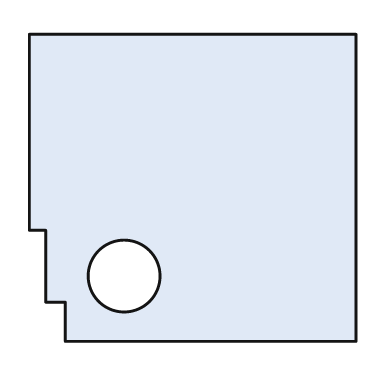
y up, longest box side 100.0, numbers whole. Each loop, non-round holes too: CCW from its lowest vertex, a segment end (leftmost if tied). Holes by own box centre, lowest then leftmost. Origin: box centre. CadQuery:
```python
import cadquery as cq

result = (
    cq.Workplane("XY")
    .moveTo(-39.0, -47.0)
    .lineTo(50.0, -47.0)
    .lineTo(50.0, 47.0)
    .lineTo(-50.0, 47.0)
    .lineTo(-50.0, -13.0)
    .lineTo(-45.0, -13.0)
    .lineTo(-45.0, -35.0)
    .lineTo(-39.0, -35.0)
    .close()
    .moveTo(-21.0, -27.0)
    .circle(11.0)
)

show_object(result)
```